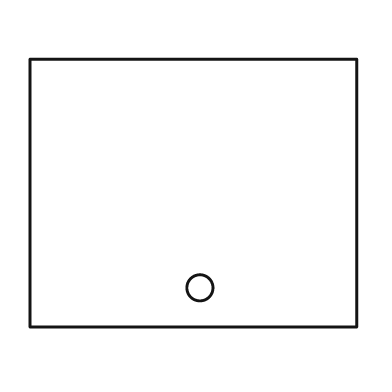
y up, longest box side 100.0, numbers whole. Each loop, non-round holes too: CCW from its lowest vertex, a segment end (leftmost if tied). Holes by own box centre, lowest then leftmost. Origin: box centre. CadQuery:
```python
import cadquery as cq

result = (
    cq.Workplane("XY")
    .moveTo(-50.0, -41.0)
    .lineTo(50.0, -41.0)
    .lineTo(50.0, 41.0)
    .lineTo(-50.0, 41.0)
    .close()
    .moveTo(2.0, -29.0)
    .circle(4.0)
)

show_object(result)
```